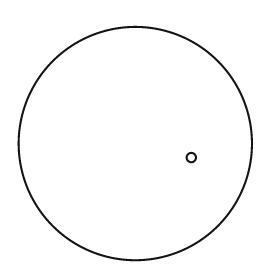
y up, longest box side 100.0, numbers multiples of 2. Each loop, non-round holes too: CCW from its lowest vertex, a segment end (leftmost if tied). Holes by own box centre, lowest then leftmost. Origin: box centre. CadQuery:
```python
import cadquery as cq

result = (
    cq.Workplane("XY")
    .moveTo(0.0, 0.0)
    .circle(50.0)
    .moveTo(24.0, -6.0)
    .circle(2.0)
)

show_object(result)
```